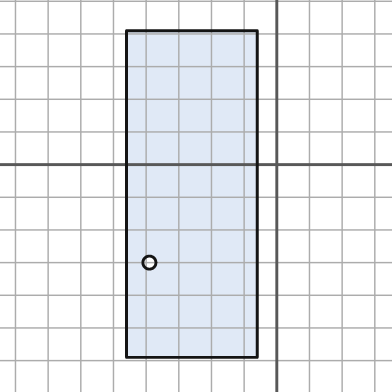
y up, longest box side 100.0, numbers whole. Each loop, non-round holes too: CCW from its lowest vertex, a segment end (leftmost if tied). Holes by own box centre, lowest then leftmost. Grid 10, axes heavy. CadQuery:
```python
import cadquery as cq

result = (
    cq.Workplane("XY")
    .moveTo(-46.0, -59.0)
    .lineTo(-6.0, -59.0)
    .lineTo(-6.0, 41.0)
    .lineTo(-46.0, 41.0)
    .close()
    .moveTo(-39.0, -30.0)
    .circle(2.0)
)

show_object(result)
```